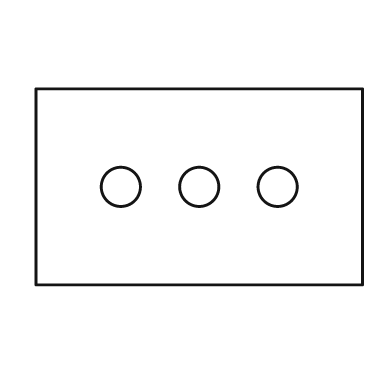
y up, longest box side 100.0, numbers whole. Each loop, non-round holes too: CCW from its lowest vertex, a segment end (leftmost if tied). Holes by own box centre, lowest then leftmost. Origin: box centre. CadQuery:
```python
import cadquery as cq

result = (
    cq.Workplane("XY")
    .moveTo(-50.0, -30.0)
    .lineTo(50.0, -30.0)
    .lineTo(50.0, 30.0)
    .lineTo(-50.0, 30.0)
    .close()
    .moveTo(-24.0, 0.0)
    .circle(6.0)
    .moveTo(0.0, 0.0)
    .circle(6.0)
    .moveTo(24.0, 0.0)
    .circle(6.0)
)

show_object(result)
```